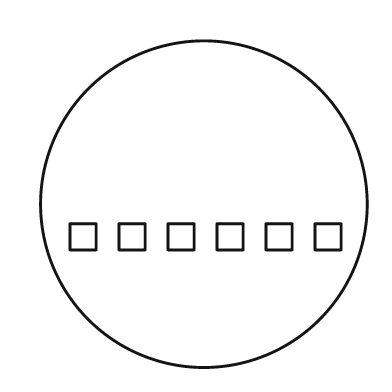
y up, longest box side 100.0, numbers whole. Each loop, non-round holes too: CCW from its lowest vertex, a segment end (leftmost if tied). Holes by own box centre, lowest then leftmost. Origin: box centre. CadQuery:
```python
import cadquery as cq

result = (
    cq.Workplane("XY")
    .moveTo(0.0, 0.0)
    .circle(50.0)
    .moveTo(-41.0, -14.0)
    .lineTo(-33.0, -14.0)
    .lineTo(-33.0, -6.0)
    .lineTo(-41.0, -6.0)
    .close()
    .moveTo(-26.0, -14.0)
    .lineTo(-18.0, -14.0)
    .lineTo(-18.0, -6.0)
    .lineTo(-26.0, -6.0)
    .close()
    .moveTo(-11.0, -14.0)
    .lineTo(-3.0, -14.0)
    .lineTo(-3.0, -6.0)
    .lineTo(-11.0, -6.0)
    .close()
    .moveTo(4.0, -14.0)
    .lineTo(12.0, -14.0)
    .lineTo(12.0, -6.0)
    .lineTo(4.0, -6.0)
    .close()
    .moveTo(19.0, -14.0)
    .lineTo(27.0, -14.0)
    .lineTo(27.0, -6.0)
    .lineTo(19.0, -6.0)
    .close()
    .moveTo(34.0, -14.0)
    .lineTo(42.0, -14.0)
    .lineTo(42.0, -6.0)
    .lineTo(34.0, -6.0)
    .close()
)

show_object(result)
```